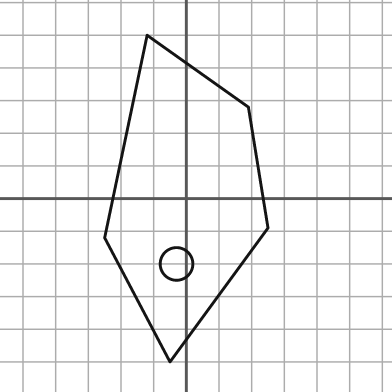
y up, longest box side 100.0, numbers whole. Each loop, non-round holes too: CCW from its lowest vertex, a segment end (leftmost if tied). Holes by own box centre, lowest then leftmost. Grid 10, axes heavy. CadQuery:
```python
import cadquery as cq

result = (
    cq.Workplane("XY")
    .moveTo(-5.0, -50.0)
    .lineTo(25.0, -9.0)
    .lineTo(19.0, 28.0)
    .lineTo(-12.0, 50.0)
    .lineTo(-25.0, -12.0)
    .close()
    .moveTo(-3.0, -20.0)
    .circle(5.0)
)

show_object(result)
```